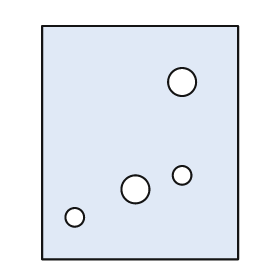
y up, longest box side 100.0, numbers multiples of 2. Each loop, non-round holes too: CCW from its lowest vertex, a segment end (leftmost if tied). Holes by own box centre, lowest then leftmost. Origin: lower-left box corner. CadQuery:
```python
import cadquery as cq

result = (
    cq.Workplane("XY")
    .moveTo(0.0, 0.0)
    .lineTo(84.0, 0.0)
    .lineTo(84.0, 100.0)
    .lineTo(0.0, 100.0)
    .close()
    .moveTo(14.0, 18.0)
    .circle(4.0)
    .moveTo(40.0, 30.0)
    .circle(6.0)
    .moveTo(60.0, 36.0)
    .circle(4.0)
    .moveTo(60.0, 76.0)
    .circle(6.0)
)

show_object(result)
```